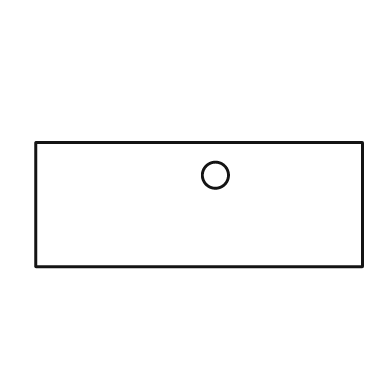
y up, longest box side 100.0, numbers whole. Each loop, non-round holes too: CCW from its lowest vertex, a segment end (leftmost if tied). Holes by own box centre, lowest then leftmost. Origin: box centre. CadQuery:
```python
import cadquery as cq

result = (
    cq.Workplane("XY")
    .moveTo(-50.0, -19.0)
    .lineTo(50.0, -19.0)
    .lineTo(50.0, 19.0)
    .lineTo(-50.0, 19.0)
    .close()
    .moveTo(5.0, 9.0)
    .circle(4.0)
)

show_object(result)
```